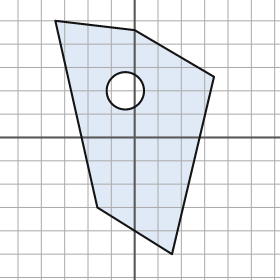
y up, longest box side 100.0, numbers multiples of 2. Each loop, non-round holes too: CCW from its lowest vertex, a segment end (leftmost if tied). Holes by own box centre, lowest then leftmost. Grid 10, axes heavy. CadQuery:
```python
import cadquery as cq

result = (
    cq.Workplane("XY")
    .moveTo(16.0, -50.0)
    .lineTo(34.0, 26.0)
    .lineTo(0.0, 46.0)
    .lineTo(-34.0, 50.0)
    .lineTo(-16.0, -30.0)
    .close()
    .moveTo(-4.0, 20.0)
    .circle(8.0)
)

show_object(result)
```